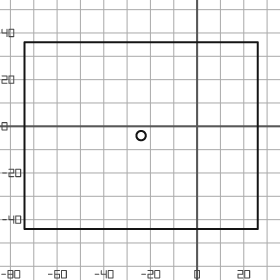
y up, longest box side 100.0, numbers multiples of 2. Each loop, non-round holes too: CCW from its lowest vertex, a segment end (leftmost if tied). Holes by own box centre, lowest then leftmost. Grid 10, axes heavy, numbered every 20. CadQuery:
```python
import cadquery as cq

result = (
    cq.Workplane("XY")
    .moveTo(-74.0, -44.0)
    .lineTo(26.0, -44.0)
    .lineTo(26.0, 36.0)
    .lineTo(-74.0, 36.0)
    .close()
    .moveTo(-24.0, -4.0)
    .circle(2.0)
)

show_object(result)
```